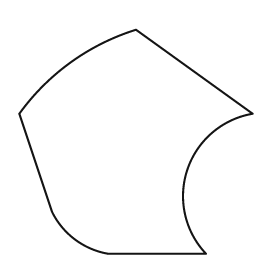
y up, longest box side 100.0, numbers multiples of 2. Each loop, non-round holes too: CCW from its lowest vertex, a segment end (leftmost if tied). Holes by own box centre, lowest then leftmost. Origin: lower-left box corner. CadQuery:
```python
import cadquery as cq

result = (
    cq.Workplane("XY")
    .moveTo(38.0, 0.0)
    .lineTo(80.0, 0.0)
    .threePointArc((72.0, 36.0), (100.0, 60.0))
    .lineTo(50.0, 96.0)
    .threePointArc((22.0, 82.0), (0.0, 60.0))
    .lineTo(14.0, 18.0)
    .threePointArc((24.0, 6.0), (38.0, 0.0))
    .close()
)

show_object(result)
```